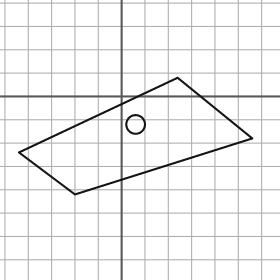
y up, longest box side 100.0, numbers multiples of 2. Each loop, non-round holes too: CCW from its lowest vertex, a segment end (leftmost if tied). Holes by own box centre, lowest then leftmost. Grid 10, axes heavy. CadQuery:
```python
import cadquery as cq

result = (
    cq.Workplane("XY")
    .moveTo(-20.0, -42.0)
    .lineTo(56.0, -18.0)
    .lineTo(24.0, 8.0)
    .lineTo(-44.0, -24.0)
    .close()
    .moveTo(6.0, -12.0)
    .circle(4.0)
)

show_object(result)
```